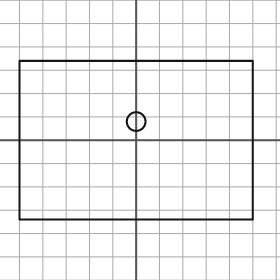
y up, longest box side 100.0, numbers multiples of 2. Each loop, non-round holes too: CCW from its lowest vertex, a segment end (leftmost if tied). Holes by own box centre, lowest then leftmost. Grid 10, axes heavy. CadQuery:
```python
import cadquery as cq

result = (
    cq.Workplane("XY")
    .moveTo(-50.0, -34.0)
    .lineTo(50.0, -34.0)
    .lineTo(50.0, 34.0)
    .lineTo(-50.0, 34.0)
    .close()
    .moveTo(0.0, 8.0)
    .circle(4.0)
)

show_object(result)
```